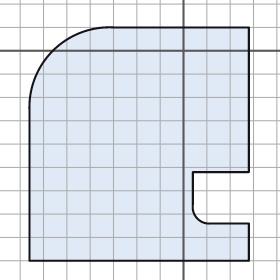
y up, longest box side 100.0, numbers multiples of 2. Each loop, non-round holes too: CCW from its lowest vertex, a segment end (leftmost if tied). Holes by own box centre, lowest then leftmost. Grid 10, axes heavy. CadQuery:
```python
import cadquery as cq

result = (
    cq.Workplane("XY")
    .moveTo(-66.0, -90.0)
    .lineTo(28.0, -90.0)
    .lineTo(28.0, -74.0)
    .lineTo(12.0, -74.0)
    .threePointArc((6.0, -72.0), (4.0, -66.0))
    .lineTo(4.0, -52.0)
    .lineTo(28.0, -52.0)
    .lineTo(28.0, 10.0)
    .lineTo(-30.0, 10.0)
    .threePointArc((-56.0, 0.0), (-66.0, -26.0))
    .close()
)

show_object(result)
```